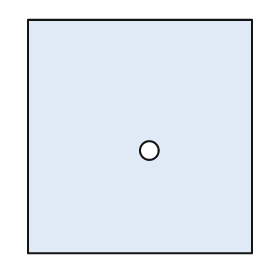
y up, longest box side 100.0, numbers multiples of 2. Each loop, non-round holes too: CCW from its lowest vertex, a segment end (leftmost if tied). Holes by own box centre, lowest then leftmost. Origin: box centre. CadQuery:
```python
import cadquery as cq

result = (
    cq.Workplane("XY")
    .moveTo(-48.0, -50.0)
    .lineTo(48.0, -50.0)
    .lineTo(48.0, 50.0)
    .lineTo(-48.0, 50.0)
    .close()
    .moveTo(4.0, -6.0)
    .circle(4.0)
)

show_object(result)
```